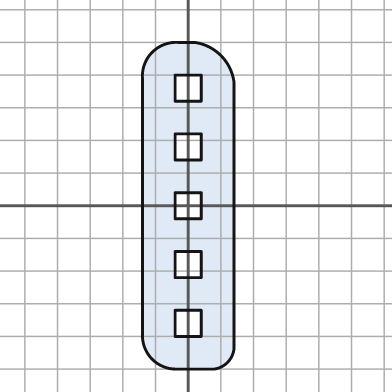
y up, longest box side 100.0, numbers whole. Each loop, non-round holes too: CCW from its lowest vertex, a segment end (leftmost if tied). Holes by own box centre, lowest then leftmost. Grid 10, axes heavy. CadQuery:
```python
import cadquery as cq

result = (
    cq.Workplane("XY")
    .moveTo(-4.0, -50.0)
    .lineTo(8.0, -50.0)
    .threePointArc((12.0, -48.0), (14.0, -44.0))
    .lineTo(14.0, 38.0)
    .threePointArc((10.0, 46.0), (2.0, 50.0))
    .lineTo(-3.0, 50.0)
    .threePointArc((-11.0, 47.0), (-14.0, 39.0))
    .lineTo(-14.0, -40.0)
    .threePointArc((-11.0, -47.0), (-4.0, -50.0))
    .close()
    .moveTo(-4.0, -40.0)
    .lineTo(4.0, -40.0)
    .lineTo(4.0, -32.0)
    .lineTo(-4.0, -32.0)
    .close()
    .moveTo(-4.0, -22.0)
    .lineTo(4.0, -22.0)
    .lineTo(4.0, -14.0)
    .lineTo(-4.0, -14.0)
    .close()
    .moveTo(-4.0, -4.0)
    .lineTo(4.0, -4.0)
    .lineTo(4.0, 4.0)
    .lineTo(-4.0, 4.0)
    .close()
    .moveTo(-4.0, 14.0)
    .lineTo(4.0, 14.0)
    .lineTo(4.0, 22.0)
    .lineTo(-4.0, 22.0)
    .close()
    .moveTo(-4.0, 32.0)
    .lineTo(4.0, 32.0)
    .lineTo(4.0, 40.0)
    .lineTo(-4.0, 40.0)
    .close()
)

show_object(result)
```